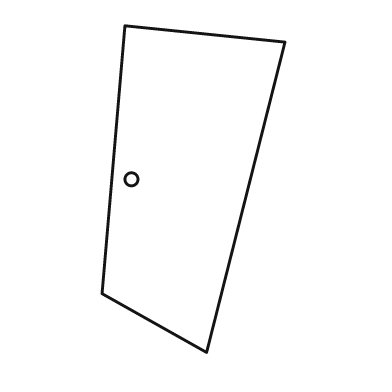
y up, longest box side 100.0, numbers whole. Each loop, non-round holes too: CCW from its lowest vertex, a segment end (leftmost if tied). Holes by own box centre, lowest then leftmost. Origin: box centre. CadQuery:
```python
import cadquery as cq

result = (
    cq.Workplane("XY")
    .moveTo(4.0, -50.0)
    .lineTo(28.0, 45.0)
    .lineTo(-21.0, 50.0)
    .lineTo(-28.0, -32.0)
    .close()
    .moveTo(-19.0, 3.0)
    .circle(2.0)
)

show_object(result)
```